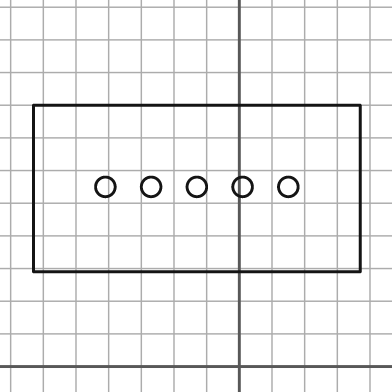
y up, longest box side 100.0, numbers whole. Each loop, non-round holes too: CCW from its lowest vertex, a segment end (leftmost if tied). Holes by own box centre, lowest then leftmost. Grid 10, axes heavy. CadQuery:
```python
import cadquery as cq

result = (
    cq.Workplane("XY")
    .moveTo(-63.0, 29.0)
    .lineTo(37.0, 29.0)
    .lineTo(37.0, 80.0)
    .lineTo(-63.0, 80.0)
    .close()
    .moveTo(-41.0, 55.0)
    .circle(3.0)
    .moveTo(-27.0, 55.0)
    .circle(3.0)
    .moveTo(-13.0, 55.0)
    .circle(3.0)
    .moveTo(1.0, 55.0)
    .circle(3.0)
    .moveTo(15.0, 55.0)
    .circle(3.0)
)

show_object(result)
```